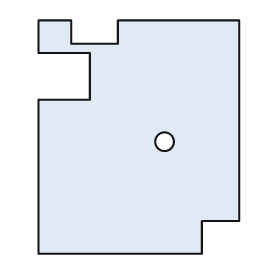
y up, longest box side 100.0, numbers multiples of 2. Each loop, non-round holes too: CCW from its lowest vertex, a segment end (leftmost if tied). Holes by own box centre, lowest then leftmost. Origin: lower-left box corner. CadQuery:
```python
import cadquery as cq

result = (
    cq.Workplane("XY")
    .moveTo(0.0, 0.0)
    .lineTo(70.0, 0.0)
    .lineTo(70.0, 14.0)
    .lineTo(86.0, 14.0)
    .lineTo(86.0, 100.0)
    .lineTo(34.0, 100.0)
    .lineTo(34.0, 90.0)
    .lineTo(14.0, 90.0)
    .lineTo(14.0, 100.0)
    .lineTo(0.0, 100.0)
    .lineTo(0.0, 86.0)
    .lineTo(22.0, 86.0)
    .lineTo(22.0, 66.0)
    .lineTo(0.0, 66.0)
    .close()
    .moveTo(54.0, 48.0)
    .circle(4.0)
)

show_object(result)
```